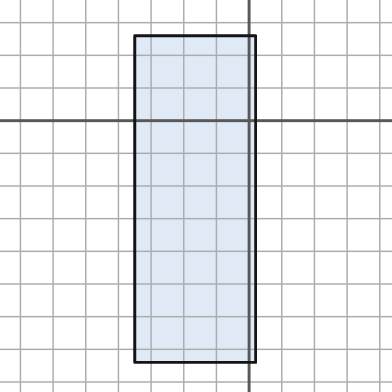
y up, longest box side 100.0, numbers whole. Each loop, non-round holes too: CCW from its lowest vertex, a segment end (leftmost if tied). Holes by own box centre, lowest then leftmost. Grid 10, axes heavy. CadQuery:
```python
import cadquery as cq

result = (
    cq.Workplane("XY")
    .moveTo(-35.0, -74.0)
    .lineTo(2.0, -74.0)
    .lineTo(2.0, 26.0)
    .lineTo(-35.0, 26.0)
    .close()
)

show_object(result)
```